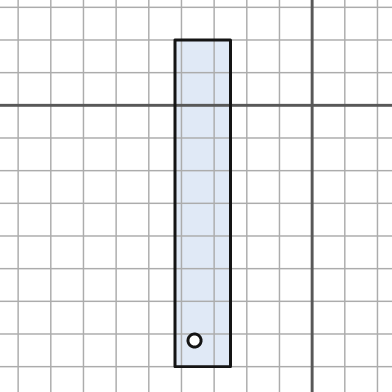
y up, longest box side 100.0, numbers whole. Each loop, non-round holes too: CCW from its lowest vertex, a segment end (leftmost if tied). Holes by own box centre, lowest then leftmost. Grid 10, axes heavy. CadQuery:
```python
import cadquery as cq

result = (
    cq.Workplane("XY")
    .moveTo(-42.0, -80.0)
    .lineTo(-25.0, -80.0)
    .lineTo(-25.0, 20.0)
    .lineTo(-42.0, 20.0)
    .close()
    .moveTo(-36.0, -72.0)
    .circle(2.0)
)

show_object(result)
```